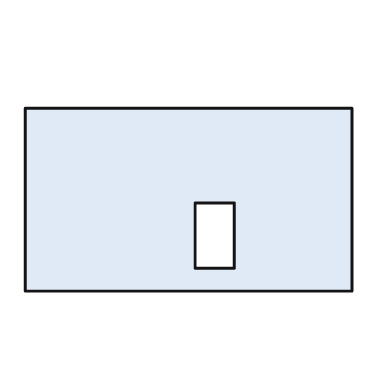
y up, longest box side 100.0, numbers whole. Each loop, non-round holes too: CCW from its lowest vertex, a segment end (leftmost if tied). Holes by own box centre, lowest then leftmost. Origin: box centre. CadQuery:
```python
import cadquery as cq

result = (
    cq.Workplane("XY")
    .moveTo(-50.0, -28.0)
    .lineTo(50.0, -28.0)
    .lineTo(50.0, 28.0)
    .lineTo(-50.0, 28.0)
    .close()
    .moveTo(2.0, -21.0)
    .lineTo(14.0, -21.0)
    .lineTo(14.0, -1.0)
    .lineTo(2.0, -1.0)
    .close()
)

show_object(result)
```